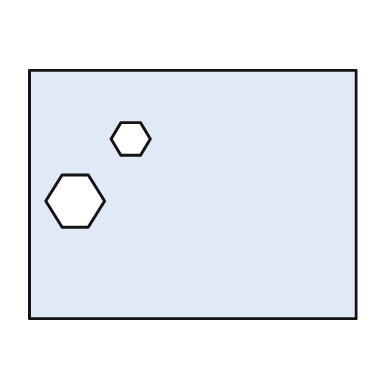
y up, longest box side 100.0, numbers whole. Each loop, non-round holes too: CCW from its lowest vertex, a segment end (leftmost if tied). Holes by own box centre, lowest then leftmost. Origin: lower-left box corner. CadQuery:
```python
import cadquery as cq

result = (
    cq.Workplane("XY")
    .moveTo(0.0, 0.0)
    .lineTo(100.0, 0.0)
    .lineTo(100.0, 76.0)
    .lineTo(0.0, 76.0)
    .close()
    .moveTo(10.0, 28.0)
    .lineTo(18.0, 28.0)
    .lineTo(23.0, 36.0)
    .lineTo(18.0, 44.0)
    .lineTo(10.0, 44.0)
    .lineTo(5.0, 36.0)
    .close()
    .moveTo(28.0, 50.0)
    .lineTo(34.0, 50.0)
    .lineTo(37.0, 55.0)
    .lineTo(34.0, 60.0)
    .lineTo(28.0, 60.0)
    .lineTo(25.0, 55.0)
    .close()
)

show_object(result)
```